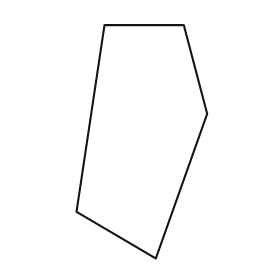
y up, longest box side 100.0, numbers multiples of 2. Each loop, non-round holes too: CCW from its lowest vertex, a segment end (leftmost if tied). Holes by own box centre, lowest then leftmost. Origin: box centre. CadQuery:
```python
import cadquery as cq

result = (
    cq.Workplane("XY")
    .moveTo(6.0, -50.0)
    .lineTo(28.0, 12.0)
    .lineTo(18.0, 50.0)
    .lineTo(-16.0, 50.0)
    .lineTo(-28.0, -30.0)
    .close()
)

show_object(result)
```